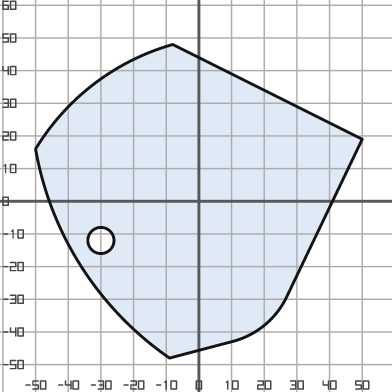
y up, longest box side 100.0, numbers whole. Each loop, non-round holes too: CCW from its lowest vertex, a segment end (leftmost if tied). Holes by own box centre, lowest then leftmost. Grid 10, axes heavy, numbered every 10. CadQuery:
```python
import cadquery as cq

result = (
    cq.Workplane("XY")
    .moveTo(-9.0, -48.0)
    .lineTo(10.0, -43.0)
    .threePointArc((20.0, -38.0), (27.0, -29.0))
    .lineTo(50.0, 19.0)
    .lineTo(-8.0, 48.0)
    .threePointArc((-32.0, 36.0), (-50.0, 16.0))
    .threePointArc((-36.0, -20.0), (-9.0, -48.0))
    .close()
    .moveTo(-30.0, -12.0)
    .circle(4.0)
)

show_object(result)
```